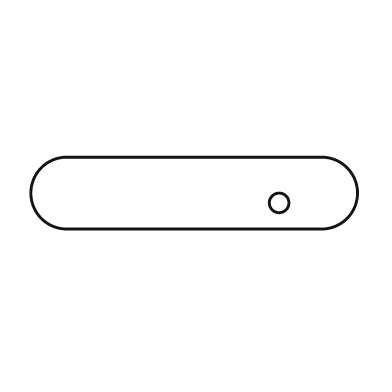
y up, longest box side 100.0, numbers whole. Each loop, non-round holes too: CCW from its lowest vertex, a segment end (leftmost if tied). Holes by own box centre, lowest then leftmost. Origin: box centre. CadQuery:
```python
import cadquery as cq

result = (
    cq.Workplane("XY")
    .moveTo(-39.0, -11.0)
    .lineTo(39.0, -11.0)
    .threePointArc((50.0, 0.0), (39.0, 11.0))
    .lineTo(-39.0, 11.0)
    .threePointArc((-50.0, 0.0), (-39.0, -11.0))
    .close()
    .moveTo(26.0, -3.0)
    .circle(3.0)
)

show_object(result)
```